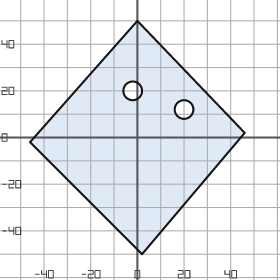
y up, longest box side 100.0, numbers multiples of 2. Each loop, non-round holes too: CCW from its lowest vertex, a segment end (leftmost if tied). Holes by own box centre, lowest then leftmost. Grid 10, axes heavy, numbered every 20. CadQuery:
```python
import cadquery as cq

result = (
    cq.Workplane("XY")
    .moveTo(2.0, -50.0)
    .lineTo(46.0, 2.0)
    .lineTo(0.0, 50.0)
    .lineTo(-46.0, -2.0)
    .close()
    .moveTo(20.0, 12.0)
    .circle(4.0)
    .moveTo(-2.0, 20.0)
    .circle(4.0)
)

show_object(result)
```